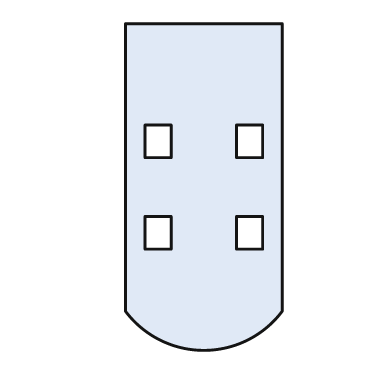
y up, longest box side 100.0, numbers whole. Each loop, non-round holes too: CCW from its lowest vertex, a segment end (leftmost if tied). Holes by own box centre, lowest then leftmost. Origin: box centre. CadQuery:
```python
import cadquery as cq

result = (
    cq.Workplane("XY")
    .moveTo(-24.0, -38.0)
    .threePointArc((0.0, -50.0), (24.0, -38.0))
    .lineTo(24.0, 50.0)
    .lineTo(-24.0, 50.0)
    .close()
    .moveTo(-18.0, -19.0)
    .lineTo(-10.0, -19.0)
    .lineTo(-10.0, -9.0)
    .lineTo(-18.0, -9.0)
    .close()
    .moveTo(10.0, -19.0)
    .lineTo(18.0, -19.0)
    .lineTo(18.0, -9.0)
    .lineTo(10.0, -9.0)
    .close()
    .moveTo(-18.0, 9.0)
    .lineTo(-10.0, 9.0)
    .lineTo(-10.0, 19.0)
    .lineTo(-18.0, 19.0)
    .close()
    .moveTo(10.0, 9.0)
    .lineTo(18.0, 9.0)
    .lineTo(18.0, 19.0)
    .lineTo(10.0, 19.0)
    .close()
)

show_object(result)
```